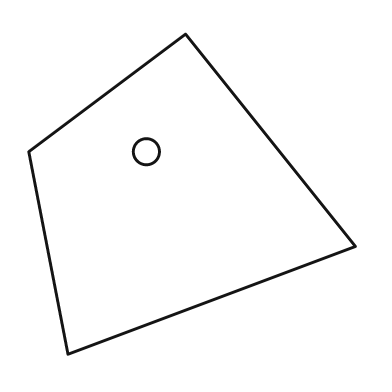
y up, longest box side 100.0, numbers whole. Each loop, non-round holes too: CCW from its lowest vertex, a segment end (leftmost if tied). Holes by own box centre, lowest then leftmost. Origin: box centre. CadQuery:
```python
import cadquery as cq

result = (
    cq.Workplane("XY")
    .moveTo(-38.0, -49.0)
    .lineTo(50.0, -16.0)
    .lineTo(-2.0, 49.0)
    .lineTo(-50.0, 13.0)
    .close()
    .moveTo(-14.0, 13.0)
    .circle(4.0)
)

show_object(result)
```